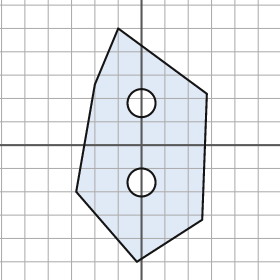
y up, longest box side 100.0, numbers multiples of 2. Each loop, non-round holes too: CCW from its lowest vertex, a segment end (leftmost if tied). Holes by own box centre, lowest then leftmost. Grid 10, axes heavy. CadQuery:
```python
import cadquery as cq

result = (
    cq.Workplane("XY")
    .moveTo(-2.0, -50.0)
    .lineTo(26.0, -32.0)
    .lineTo(28.0, 22.0)
    .lineTo(-10.0, 50.0)
    .lineTo(-20.0, 26.0)
    .lineTo(-28.0, -20.0)
    .close()
    .moveTo(0.0, -16.0)
    .circle(6.0)
    .moveTo(0.0, 18.0)
    .circle(6.0)
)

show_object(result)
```